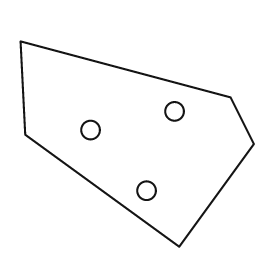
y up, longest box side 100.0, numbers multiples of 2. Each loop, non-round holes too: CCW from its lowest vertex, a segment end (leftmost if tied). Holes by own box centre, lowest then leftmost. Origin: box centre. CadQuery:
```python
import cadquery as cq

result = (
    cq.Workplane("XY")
    .moveTo(18.0, -44.0)
    .lineTo(50.0, 0.0)
    .lineTo(40.0, 20.0)
    .lineTo(-50.0, 44.0)
    .lineTo(-48.0, 4.0)
    .close()
    .moveTo(4.0, -20.0)
    .circle(4.0)
    .moveTo(-20.0, 6.0)
    .circle(4.0)
    .moveTo(16.0, 14.0)
    .circle(4.0)
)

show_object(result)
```